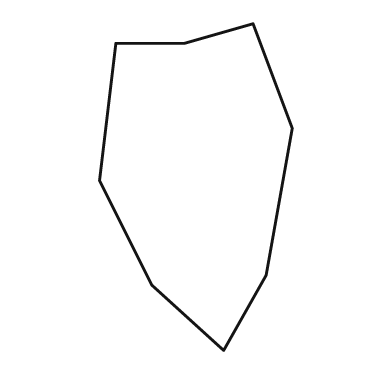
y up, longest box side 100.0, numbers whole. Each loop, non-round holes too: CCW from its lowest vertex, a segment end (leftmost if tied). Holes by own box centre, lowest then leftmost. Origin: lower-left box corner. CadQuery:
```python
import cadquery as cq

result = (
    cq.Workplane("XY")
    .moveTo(38.0, 0.0)
    .lineTo(51.0, 23.0)
    .lineTo(59.0, 68.0)
    .lineTo(47.0, 100.0)
    .lineTo(26.0, 94.0)
    .lineTo(5.0, 94.0)
    .lineTo(0.0, 52.0)
    .lineTo(16.0, 20.0)
    .close()
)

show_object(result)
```